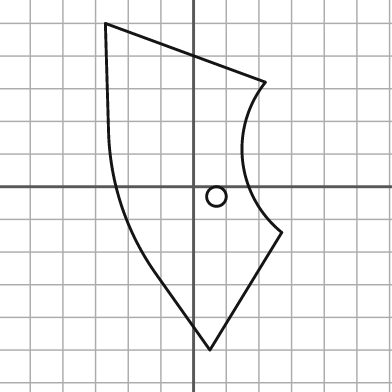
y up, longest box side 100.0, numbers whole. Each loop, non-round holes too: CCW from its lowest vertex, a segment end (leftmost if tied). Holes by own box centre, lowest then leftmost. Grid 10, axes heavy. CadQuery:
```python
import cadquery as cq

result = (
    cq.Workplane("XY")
    .moveTo(5.0, -50.0)
    .lineTo(27.0, -14.0)
    .threePointArc((15.0, 8.0), (22.0, 32.0))
    .lineTo(-27.0, 50.0)
    .lineTo(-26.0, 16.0)
    .threePointArc((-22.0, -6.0), (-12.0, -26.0))
    .close()
    .moveTo(7.0, -3.0)
    .circle(3.0)
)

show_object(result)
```